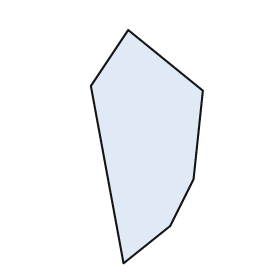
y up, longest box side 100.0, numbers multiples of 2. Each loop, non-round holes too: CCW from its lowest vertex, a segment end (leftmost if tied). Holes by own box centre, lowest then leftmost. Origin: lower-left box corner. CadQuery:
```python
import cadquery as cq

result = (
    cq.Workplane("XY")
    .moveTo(14.0, 0.0)
    .lineTo(34.0, 16.0)
    .lineTo(44.0, 36.0)
    .lineTo(48.0, 74.0)
    .lineTo(16.0, 100.0)
    .lineTo(0.0, 76.0)
    .close()
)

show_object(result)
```